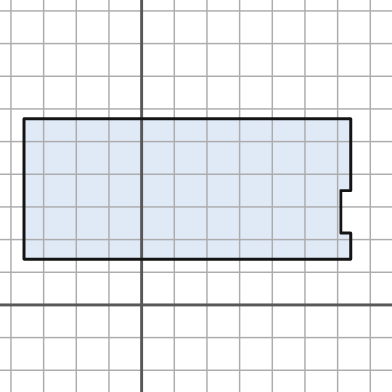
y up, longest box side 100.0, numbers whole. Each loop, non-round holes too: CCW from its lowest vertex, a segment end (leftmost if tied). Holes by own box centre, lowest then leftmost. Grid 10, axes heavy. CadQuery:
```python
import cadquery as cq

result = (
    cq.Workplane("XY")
    .moveTo(-36.0, 14.0)
    .lineTo(64.0, 14.0)
    .lineTo(64.0, 22.0)
    .lineTo(61.0, 22.0)
    .lineTo(61.0, 35.0)
    .lineTo(64.0, 35.0)
    .lineTo(64.0, 57.0)
    .lineTo(-36.0, 57.0)
    .close()
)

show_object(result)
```